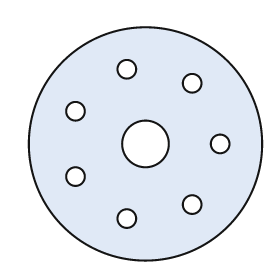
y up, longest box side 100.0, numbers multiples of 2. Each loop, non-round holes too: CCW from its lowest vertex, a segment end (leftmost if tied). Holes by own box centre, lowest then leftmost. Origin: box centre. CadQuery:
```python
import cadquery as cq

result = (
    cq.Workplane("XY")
    .moveTo(0.0, 0.0)
    .circle(50.0)
    .moveTo(-8.0, -32.0)
    .circle(4.0)
    .moveTo(20.0, -26.0)
    .circle(4.0)
    .moveTo(-30.0, -14.0)
    .circle(4.0)
    .moveTo(0.0, 0.0)
    .circle(10.0)
    .moveTo(32.0, 0.0)
    .circle(4.0)
    .moveTo(-30.0, 14.0)
    .circle(4.0)
    .moveTo(20.0, 26.0)
    .circle(4.0)
    .moveTo(-8.0, 32.0)
    .circle(4.0)
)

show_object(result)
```